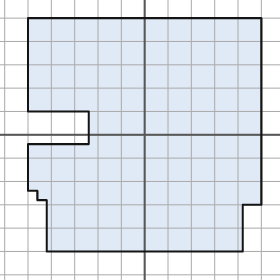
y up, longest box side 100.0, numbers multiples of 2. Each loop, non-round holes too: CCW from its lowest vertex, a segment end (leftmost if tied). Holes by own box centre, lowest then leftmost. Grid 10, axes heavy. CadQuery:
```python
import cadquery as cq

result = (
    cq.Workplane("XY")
    .moveTo(-42.0, -50.0)
    .lineTo(42.0, -50.0)
    .lineTo(42.0, -30.0)
    .lineTo(50.0, -30.0)
    .lineTo(50.0, 50.0)
    .lineTo(-50.0, 50.0)
    .lineTo(-50.0, 10.0)
    .lineTo(-24.0, 10.0)
    .lineTo(-24.0, -4.0)
    .lineTo(-50.0, -4.0)
    .lineTo(-50.0, -24.0)
    .lineTo(-46.0, -24.0)
    .lineTo(-46.0, -28.0)
    .lineTo(-42.0, -28.0)
    .close()
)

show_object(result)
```